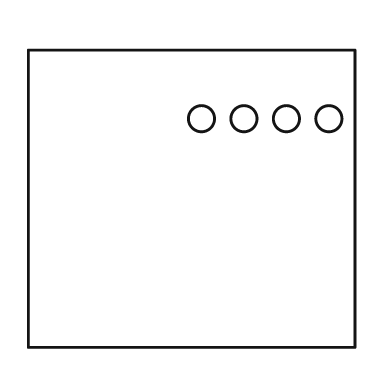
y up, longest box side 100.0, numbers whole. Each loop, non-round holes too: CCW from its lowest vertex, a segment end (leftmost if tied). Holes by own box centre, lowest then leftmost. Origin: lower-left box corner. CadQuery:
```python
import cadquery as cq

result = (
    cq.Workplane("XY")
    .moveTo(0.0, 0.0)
    .lineTo(100.0, 0.0)
    .lineTo(100.0, 91.0)
    .lineTo(0.0, 91.0)
    .close()
    .moveTo(53.0, 70.0)
    .circle(4.0)
    .moveTo(66.0, 70.0)
    .circle(4.0)
    .moveTo(79.0, 70.0)
    .circle(4.0)
    .moveTo(92.0, 70.0)
    .circle(4.0)
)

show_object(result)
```